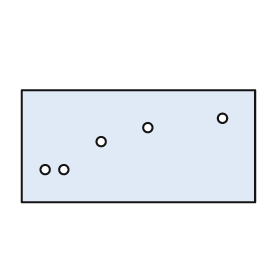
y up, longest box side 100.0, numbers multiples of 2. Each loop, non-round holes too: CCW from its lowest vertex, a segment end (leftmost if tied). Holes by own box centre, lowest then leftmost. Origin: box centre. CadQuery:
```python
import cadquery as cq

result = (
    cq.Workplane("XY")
    .moveTo(-50.0, -24.0)
    .lineTo(50.0, -24.0)
    .lineTo(50.0, 24.0)
    .lineTo(-50.0, 24.0)
    .close()
    .moveTo(-40.0, -10.0)
    .circle(2.0)
    .moveTo(-32.0, -10.0)
    .circle(2.0)
    .moveTo(-16.0, 2.0)
    .circle(2.0)
    .moveTo(4.0, 8.0)
    .circle(2.0)
    .moveTo(36.0, 12.0)
    .circle(2.0)
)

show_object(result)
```